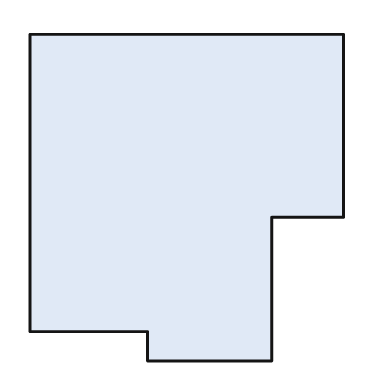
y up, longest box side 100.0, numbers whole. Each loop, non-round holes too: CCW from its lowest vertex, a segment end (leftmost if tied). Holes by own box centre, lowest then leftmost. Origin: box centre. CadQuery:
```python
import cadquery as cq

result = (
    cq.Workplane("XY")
    .moveTo(-12.0, -50.0)
    .lineTo(26.0, -50.0)
    .lineTo(26.0, -6.0)
    .lineTo(48.0, -6.0)
    .lineTo(48.0, 50.0)
    .lineTo(-48.0, 50.0)
    .lineTo(-48.0, -41.0)
    .lineTo(-12.0, -41.0)
    .close()
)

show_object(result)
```